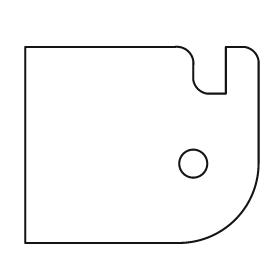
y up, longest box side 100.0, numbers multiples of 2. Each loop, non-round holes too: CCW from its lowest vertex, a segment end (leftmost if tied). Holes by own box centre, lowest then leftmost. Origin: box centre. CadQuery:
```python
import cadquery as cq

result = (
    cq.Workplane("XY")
    .moveTo(-50.0, -42.0)
    .lineTo(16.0, -42.0)
    .threePointArc((40.0, -32.0), (50.0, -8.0))
    .lineTo(50.0, 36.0)
    .threePointArc((48.0, 40.0), (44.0, 42.0))
    .lineTo(36.0, 42.0)
    .lineTo(36.0, 22.0)
    .lineTo(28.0, 22.0)
    .threePointArc((24.0, 24.0), (22.0, 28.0))
    .lineTo(22.0, 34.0)
    .threePointArc((20.0, 40.0), (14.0, 42.0))
    .lineTo(-50.0, 42.0)
    .close()
    .moveTo(22.0, -8.0)
    .circle(6.0)
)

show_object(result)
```